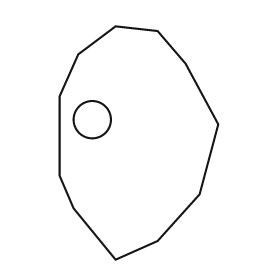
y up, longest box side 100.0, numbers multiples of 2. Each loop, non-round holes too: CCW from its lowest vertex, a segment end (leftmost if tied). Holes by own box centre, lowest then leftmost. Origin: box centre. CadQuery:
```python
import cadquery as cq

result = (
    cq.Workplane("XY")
    .moveTo(-10.0, -50.0)
    .lineTo(8.0, -42.0)
    .lineTo(26.0, -22.0)
    .lineTo(34.0, 8.0)
    .lineTo(20.0, 34.0)
    .lineTo(8.0, 48.0)
    .lineTo(-10.0, 50.0)
    .lineTo(-26.0, 38.0)
    .lineTo(-34.0, 20.0)
    .lineTo(-34.0, -14.0)
    .lineTo(-28.0, -28.0)
    .close()
    .moveTo(-20.0, 10.0)
    .circle(8.0)
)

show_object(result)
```